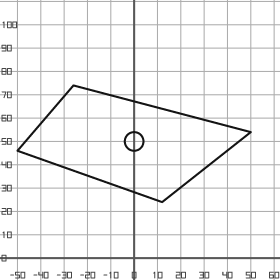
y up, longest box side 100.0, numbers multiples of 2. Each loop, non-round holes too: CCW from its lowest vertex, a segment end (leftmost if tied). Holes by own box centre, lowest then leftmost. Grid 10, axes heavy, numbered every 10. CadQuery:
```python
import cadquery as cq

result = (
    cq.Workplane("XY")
    .moveTo(12.0, 24.0)
    .lineTo(50.0, 54.0)
    .lineTo(-26.0, 74.0)
    .lineTo(-50.0, 46.0)
    .close()
    .moveTo(0.0, 50.0)
    .circle(4.0)
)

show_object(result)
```